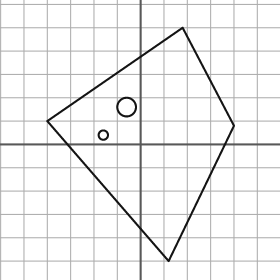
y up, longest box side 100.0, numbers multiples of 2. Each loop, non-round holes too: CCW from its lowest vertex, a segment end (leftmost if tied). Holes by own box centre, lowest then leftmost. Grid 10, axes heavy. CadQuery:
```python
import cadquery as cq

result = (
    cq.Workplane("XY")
    .moveTo(12.0, -50.0)
    .lineTo(40.0, 8.0)
    .lineTo(18.0, 50.0)
    .lineTo(-40.0, 10.0)
    .close()
    .moveTo(-16.0, 4.0)
    .circle(2.0)
    .moveTo(-6.0, 16.0)
    .circle(4.0)
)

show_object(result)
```